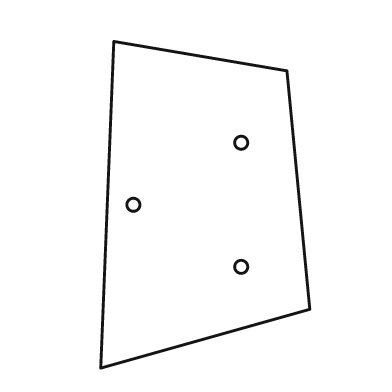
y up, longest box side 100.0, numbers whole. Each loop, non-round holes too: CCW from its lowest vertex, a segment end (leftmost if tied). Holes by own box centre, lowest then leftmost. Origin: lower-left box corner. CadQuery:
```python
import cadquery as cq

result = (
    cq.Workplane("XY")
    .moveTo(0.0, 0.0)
    .lineTo(64.0, 18.0)
    .lineTo(57.0, 91.0)
    .lineTo(4.0, 100.0)
    .close()
    .moveTo(43.0, 31.0)
    .circle(2.0)
    .moveTo(10.0, 50.0)
    .circle(2.0)
    .moveTo(43.0, 69.0)
    .circle(2.0)
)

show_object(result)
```